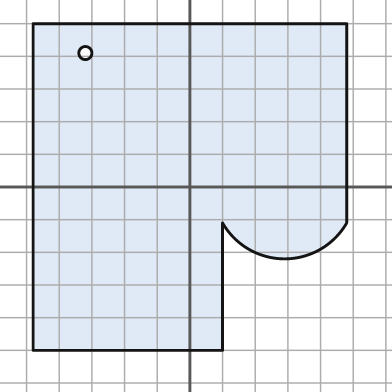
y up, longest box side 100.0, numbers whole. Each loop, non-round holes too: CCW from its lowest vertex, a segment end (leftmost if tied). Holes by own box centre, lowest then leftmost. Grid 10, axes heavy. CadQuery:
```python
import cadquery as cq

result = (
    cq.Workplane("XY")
    .moveTo(-48.0, -50.0)
    .lineTo(10.0, -50.0)
    .lineTo(10.0, -11.0)
    .threePointArc((29.0, -22.0), (48.0, -11.0))
    .lineTo(48.0, 50.0)
    .lineTo(-48.0, 50.0)
    .close()
    .moveTo(-32.0, 41.0)
    .circle(2.0)
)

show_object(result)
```